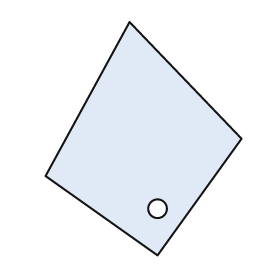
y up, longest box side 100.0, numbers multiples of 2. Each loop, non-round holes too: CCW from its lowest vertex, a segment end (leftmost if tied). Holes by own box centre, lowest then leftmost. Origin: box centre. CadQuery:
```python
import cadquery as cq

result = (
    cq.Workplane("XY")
    .moveTo(6.0, -50.0)
    .lineTo(42.0, 0.0)
    .lineTo(-6.0, 50.0)
    .lineTo(-42.0, -16.0)
    .close()
    .moveTo(6.0, -30.0)
    .circle(4.0)
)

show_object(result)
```